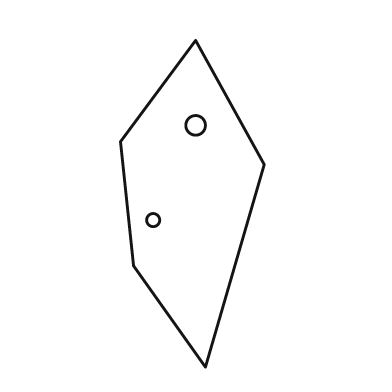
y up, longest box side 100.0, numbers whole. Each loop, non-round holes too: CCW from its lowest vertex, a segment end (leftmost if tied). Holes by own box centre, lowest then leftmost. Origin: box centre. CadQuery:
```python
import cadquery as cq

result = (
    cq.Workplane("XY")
    .moveTo(4.0, -50.0)
    .lineTo(22.0, 12.0)
    .lineTo(1.0, 50.0)
    .lineTo(-22.0, 19.0)
    .lineTo(-18.0, -19.0)
    .close()
    .moveTo(-12.0, -5.0)
    .circle(2.0)
    .moveTo(1.0, 24.0)
    .circle(3.0)
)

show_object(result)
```